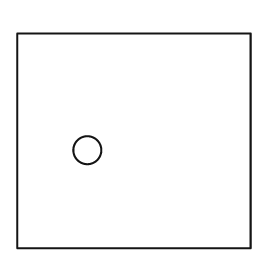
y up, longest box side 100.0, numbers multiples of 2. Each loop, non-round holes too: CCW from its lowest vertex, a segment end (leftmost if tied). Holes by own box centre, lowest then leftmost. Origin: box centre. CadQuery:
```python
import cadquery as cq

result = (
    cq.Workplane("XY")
    .moveTo(-50.0, -46.0)
    .lineTo(50.0, -46.0)
    .lineTo(50.0, 46.0)
    .lineTo(-50.0, 46.0)
    .close()
    .moveTo(-20.0, -4.0)
    .circle(6.0)
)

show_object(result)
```